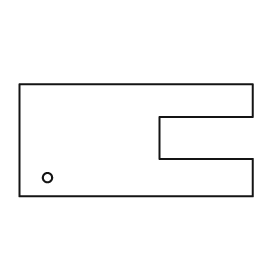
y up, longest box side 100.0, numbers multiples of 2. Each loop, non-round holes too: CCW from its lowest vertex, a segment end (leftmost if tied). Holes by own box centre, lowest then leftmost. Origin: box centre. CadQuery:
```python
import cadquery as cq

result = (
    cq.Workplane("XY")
    .moveTo(-50.0, -24.0)
    .lineTo(50.0, -24.0)
    .lineTo(50.0, -8.0)
    .lineTo(10.0, -8.0)
    .lineTo(10.0, 10.0)
    .lineTo(50.0, 10.0)
    .lineTo(50.0, 24.0)
    .lineTo(-50.0, 24.0)
    .close()
    .moveTo(-38.0, -16.0)
    .circle(2.0)
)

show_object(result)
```